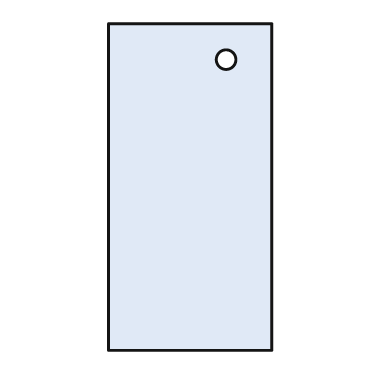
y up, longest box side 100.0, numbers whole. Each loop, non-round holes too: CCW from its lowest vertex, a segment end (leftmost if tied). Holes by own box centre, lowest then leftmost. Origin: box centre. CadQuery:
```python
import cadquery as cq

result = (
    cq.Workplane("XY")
    .moveTo(-25.0, -50.0)
    .lineTo(25.0, -50.0)
    .lineTo(25.0, 50.0)
    .lineTo(-25.0, 50.0)
    .close()
    .moveTo(11.0, 39.0)
    .circle(3.0)
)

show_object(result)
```